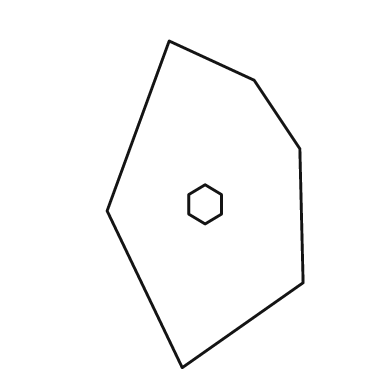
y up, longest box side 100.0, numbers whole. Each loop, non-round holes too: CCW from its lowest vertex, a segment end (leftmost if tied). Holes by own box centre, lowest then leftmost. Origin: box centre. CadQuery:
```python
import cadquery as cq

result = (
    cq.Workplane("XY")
    .moveTo(-7.0, -50.0)
    .lineTo(30.0, -24.0)
    .lineTo(29.0, 17.0)
    .lineTo(15.0, 38.0)
    .lineTo(-11.0, 50.0)
    .lineTo(-30.0, -2.0)
    .close()
    .moveTo(0.0, -6.0)
    .lineTo(5.0, -3.0)
    .lineTo(5.0, 3.0)
    .lineTo(0.0, 6.0)
    .lineTo(-5.0, 3.0)
    .lineTo(-5.0, -3.0)
    .close()
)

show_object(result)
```